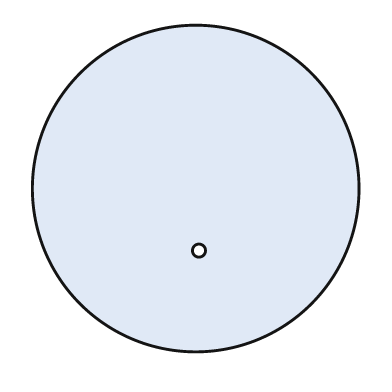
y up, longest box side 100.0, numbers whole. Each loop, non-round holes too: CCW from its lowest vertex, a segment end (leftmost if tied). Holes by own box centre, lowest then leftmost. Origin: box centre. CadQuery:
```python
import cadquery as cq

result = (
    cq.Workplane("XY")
    .moveTo(0.0, 0.0)
    .circle(50.0)
    .moveTo(1.0, -19.0)
    .circle(2.0)
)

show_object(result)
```